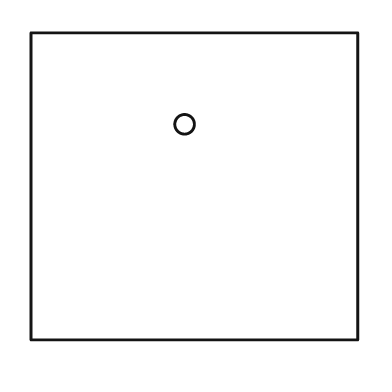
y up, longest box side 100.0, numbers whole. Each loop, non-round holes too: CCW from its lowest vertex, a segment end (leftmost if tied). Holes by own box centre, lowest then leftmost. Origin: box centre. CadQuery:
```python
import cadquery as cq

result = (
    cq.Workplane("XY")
    .moveTo(-50.0, -47.0)
    .lineTo(50.0, -47.0)
    .lineTo(50.0, 47.0)
    .lineTo(-50.0, 47.0)
    .close()
    .moveTo(-3.0, 19.0)
    .circle(3.0)
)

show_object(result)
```